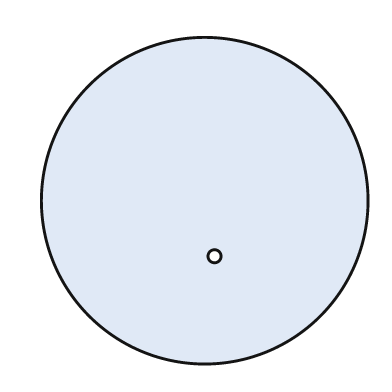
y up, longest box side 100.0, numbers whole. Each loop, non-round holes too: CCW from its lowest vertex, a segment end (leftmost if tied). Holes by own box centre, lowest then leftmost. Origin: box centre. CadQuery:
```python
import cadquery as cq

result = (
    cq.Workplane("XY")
    .moveTo(0.0, 0.0)
    .circle(50.0)
    .moveTo(3.0, -17.0)
    .circle(2.0)
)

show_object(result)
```